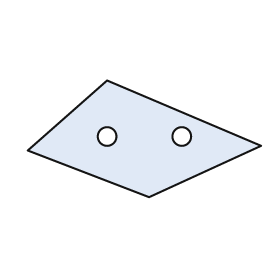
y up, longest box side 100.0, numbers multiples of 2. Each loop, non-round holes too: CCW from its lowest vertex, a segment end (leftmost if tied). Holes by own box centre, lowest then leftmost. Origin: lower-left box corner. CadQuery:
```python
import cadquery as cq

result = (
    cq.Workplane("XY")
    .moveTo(52.0, 0.0)
    .lineTo(100.0, 22.0)
    .lineTo(34.0, 50.0)
    .lineTo(0.0, 20.0)
    .close()
    .moveTo(34.0, 26.0)
    .circle(4.0)
    .moveTo(66.0, 26.0)
    .circle(4.0)
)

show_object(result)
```